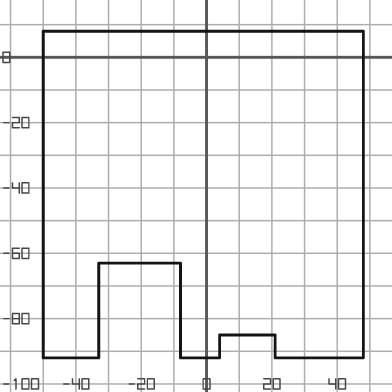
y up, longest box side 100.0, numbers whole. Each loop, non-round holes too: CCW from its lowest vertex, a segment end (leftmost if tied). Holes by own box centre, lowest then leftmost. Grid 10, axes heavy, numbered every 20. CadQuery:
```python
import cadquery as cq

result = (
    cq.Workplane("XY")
    .moveTo(-50.0, -92.0)
    .lineTo(-33.0, -92.0)
    .lineTo(-33.0, -63.0)
    .lineTo(-8.0, -63.0)
    .lineTo(-8.0, -92.0)
    .lineTo(4.0, -92.0)
    .lineTo(4.0, -85.0)
    .lineTo(21.0, -85.0)
    .lineTo(21.0, -92.0)
    .lineTo(48.0, -92.0)
    .lineTo(48.0, 8.0)
    .lineTo(-50.0, 8.0)
    .close()
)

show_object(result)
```